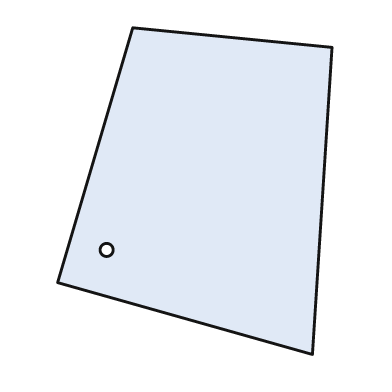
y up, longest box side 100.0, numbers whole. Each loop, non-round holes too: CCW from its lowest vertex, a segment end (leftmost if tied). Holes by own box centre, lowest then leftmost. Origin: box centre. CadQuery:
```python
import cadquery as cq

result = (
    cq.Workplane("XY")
    .moveTo(36.0, -50.0)
    .lineTo(42.0, 44.0)
    .lineTo(-19.0, 50.0)
    .lineTo(-42.0, -28.0)
    .close()
    .moveTo(-27.0, -18.0)
    .circle(2.0)
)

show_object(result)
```